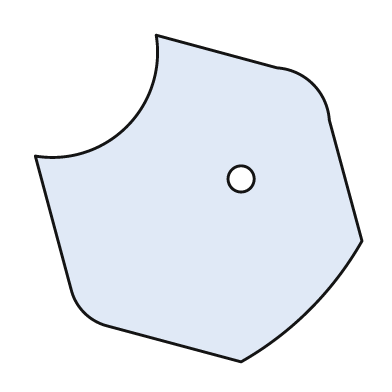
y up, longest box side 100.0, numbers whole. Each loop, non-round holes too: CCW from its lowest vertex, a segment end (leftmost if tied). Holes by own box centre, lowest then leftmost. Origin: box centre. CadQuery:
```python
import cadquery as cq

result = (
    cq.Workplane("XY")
    .moveTo(13.0, -50.0)
    .threePointArc((34.0, -34.0), (50.0, -13.0))
    .lineTo(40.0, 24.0)
    .threePointArc((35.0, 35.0), (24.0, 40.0))
    .lineTo(-13.0, 50.0)
    .threePointArc((-22.0, 22.0), (-50.0, 13.0))
    .lineTo(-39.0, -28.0)
    .threePointArc((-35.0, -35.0), (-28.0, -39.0))
    .close()
    .moveTo(13.0, 6.0)
    .circle(4.0)
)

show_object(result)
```